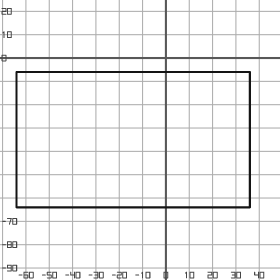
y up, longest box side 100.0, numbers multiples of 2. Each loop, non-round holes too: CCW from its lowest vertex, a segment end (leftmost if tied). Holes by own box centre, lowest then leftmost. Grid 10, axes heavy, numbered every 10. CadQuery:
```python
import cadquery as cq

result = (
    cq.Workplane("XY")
    .moveTo(-64.0, -64.0)
    .lineTo(36.0, -64.0)
    .lineTo(36.0, -6.0)
    .lineTo(-64.0, -6.0)
    .close()
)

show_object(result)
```